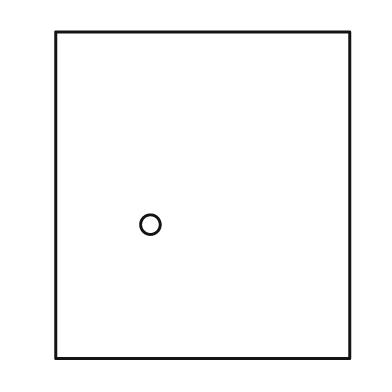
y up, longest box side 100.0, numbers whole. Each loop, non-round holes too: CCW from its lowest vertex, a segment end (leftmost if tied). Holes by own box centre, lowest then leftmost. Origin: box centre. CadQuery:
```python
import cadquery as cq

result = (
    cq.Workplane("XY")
    .moveTo(-45.0, -50.0)
    .lineTo(45.0, -50.0)
    .lineTo(45.0, 50.0)
    .lineTo(-45.0, 50.0)
    .close()
    .moveTo(-16.0, -9.0)
    .circle(3.0)
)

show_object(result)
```